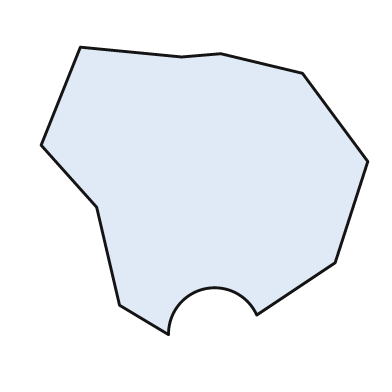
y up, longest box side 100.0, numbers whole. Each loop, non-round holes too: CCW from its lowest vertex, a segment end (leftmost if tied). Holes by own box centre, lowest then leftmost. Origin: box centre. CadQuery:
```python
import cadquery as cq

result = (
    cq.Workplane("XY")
    .moveTo(-11.0, -44.0)
    .threePointArc((0.0, -30.0), (16.0, -38.0))
    .lineTo(40.0, -22.0)
    .lineTo(50.0, 9.0)
    .lineTo(30.0, 36.0)
    .lineTo(5.0, 42.0)
    .lineTo(-7.0, 41.0)
    .lineTo(-38.0, 44.0)
    .lineTo(-50.0, 14.0)
    .lineTo(-33.0, -5.0)
    .lineTo(-26.0, -35.0)
    .close()
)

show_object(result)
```